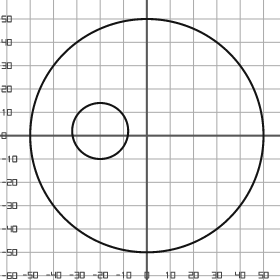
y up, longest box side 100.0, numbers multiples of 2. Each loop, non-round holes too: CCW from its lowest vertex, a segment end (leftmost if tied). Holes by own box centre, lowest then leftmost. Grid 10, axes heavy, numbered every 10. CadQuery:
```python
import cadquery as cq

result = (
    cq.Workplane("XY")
    .moveTo(0.0, 0.0)
    .circle(50.0)
    .moveTo(-20.0, 2.0)
    .circle(12.0)
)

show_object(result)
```